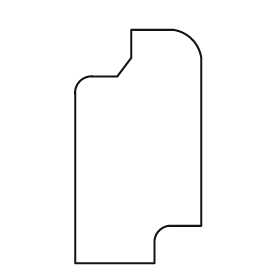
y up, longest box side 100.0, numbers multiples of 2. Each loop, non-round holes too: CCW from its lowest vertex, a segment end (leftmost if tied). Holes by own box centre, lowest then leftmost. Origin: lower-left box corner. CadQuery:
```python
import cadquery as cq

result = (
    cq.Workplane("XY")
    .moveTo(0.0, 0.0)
    .lineTo(34.0, 0.0)
    .lineTo(34.0, 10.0)
    .threePointArc((36.0, 14.0), (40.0, 16.0))
    .lineTo(54.0, 16.0)
    .lineTo(54.0, 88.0)
    .threePointArc((50.0, 96.0), (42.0, 100.0))
    .lineTo(24.0, 100.0)
    .lineTo(24.0, 88.0)
    .lineTo(18.0, 80.0)
    .lineTo(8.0, 80.0)
    .threePointArc((2.0, 78.0), (0.0, 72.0))
    .close()
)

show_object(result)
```